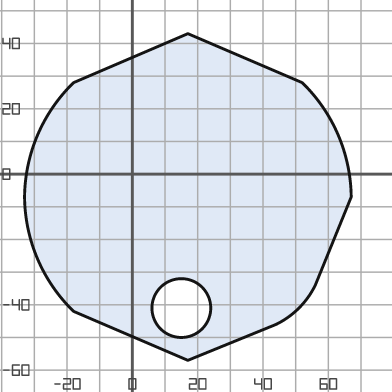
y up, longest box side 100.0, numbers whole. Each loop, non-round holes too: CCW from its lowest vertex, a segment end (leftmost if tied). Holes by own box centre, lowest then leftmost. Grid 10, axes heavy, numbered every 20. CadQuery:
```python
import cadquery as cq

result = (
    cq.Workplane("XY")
    .moveTo(17.0, -57.0)
    .lineTo(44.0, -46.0)
    .threePointArc((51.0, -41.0), (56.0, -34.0))
    .lineTo(67.0, -7.0)
    .threePointArc((63.0, 12.0), (52.0, 28.0))
    .lineTo(17.0, 43.0)
    .lineTo(-18.0, 28.0)
    .threePointArc((-29.0, 12.0), (-33.0, -7.0))
    .threePointArc((-29.0, -26.0), (-18.0, -42.0))
    .close()
    .moveTo(15.0, -41.0)
    .circle(9.0)
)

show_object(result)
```